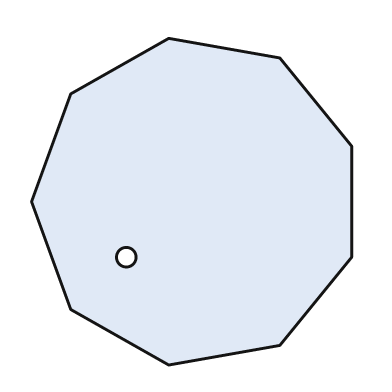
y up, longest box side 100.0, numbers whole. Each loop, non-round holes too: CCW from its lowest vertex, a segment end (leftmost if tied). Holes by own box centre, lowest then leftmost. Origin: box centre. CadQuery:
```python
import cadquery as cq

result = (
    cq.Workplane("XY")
    .moveTo(-7.0, -50.0)
    .lineTo(27.0, -44.0)
    .lineTo(49.0, -17.0)
    .lineTo(49.0, 17.0)
    .lineTo(27.0, 44.0)
    .lineTo(-7.0, 50.0)
    .lineTo(-37.0, 33.0)
    .lineTo(-49.0, 0.0)
    .lineTo(-37.0, -33.0)
    .close()
    .moveTo(-20.0, -17.0)
    .circle(3.0)
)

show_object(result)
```